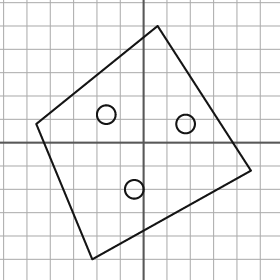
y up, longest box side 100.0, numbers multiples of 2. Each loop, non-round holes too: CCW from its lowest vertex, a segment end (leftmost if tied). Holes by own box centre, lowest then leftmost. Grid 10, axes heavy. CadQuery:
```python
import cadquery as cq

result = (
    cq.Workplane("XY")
    .moveTo(-22.0, -50.0)
    .lineTo(46.0, -12.0)
    .lineTo(6.0, 50.0)
    .lineTo(-46.0, 8.0)
    .close()
    .moveTo(-4.0, -20.0)
    .circle(4.0)
    .moveTo(18.0, 8.0)
    .circle(4.0)
    .moveTo(-16.0, 12.0)
    .circle(4.0)
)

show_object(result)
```